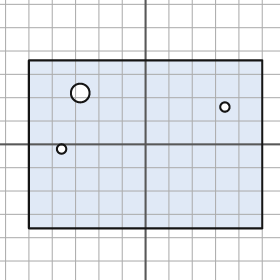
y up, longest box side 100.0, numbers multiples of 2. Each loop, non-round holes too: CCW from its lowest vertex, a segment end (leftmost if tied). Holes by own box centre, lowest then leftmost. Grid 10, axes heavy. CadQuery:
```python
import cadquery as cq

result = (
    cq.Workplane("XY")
    .moveTo(-50.0, -36.0)
    .lineTo(50.0, -36.0)
    .lineTo(50.0, 36.0)
    .lineTo(-50.0, 36.0)
    .close()
    .moveTo(-36.0, -2.0)
    .circle(2.0)
    .moveTo(34.0, 16.0)
    .circle(2.0)
    .moveTo(-28.0, 22.0)
    .circle(4.0)
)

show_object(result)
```